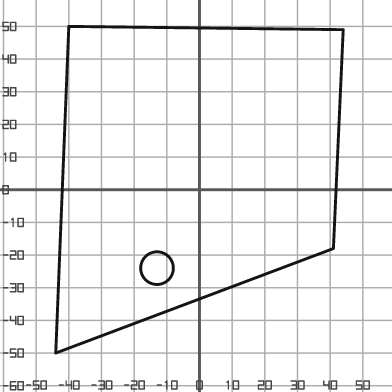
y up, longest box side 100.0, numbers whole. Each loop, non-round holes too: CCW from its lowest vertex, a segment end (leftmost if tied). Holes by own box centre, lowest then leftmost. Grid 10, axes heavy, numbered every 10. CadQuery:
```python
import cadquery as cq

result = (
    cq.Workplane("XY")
    .moveTo(-44.0, -50.0)
    .lineTo(41.0, -18.0)
    .lineTo(44.0, 49.0)
    .lineTo(-40.0, 50.0)
    .close()
    .moveTo(-13.0, -24.0)
    .circle(5.0)
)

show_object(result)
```